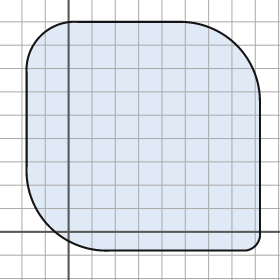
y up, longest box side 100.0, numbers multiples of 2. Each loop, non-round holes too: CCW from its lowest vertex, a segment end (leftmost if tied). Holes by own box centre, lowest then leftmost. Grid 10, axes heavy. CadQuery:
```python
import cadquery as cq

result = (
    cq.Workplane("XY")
    .moveTo(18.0, -8.0)
    .lineTo(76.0, -8.0)
    .threePointArc((80.0, -6.0), (82.0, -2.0))
    .lineTo(82.0, 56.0)
    .threePointArc((72.0, 80.0), (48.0, 90.0))
    .lineTo(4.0, 90.0)
    .threePointArc((-12.0, 84.0), (-18.0, 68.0))
    .lineTo(-18.0, 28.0)
    .threePointArc((-8.0, 2.0), (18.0, -8.0))
    .close()
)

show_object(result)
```